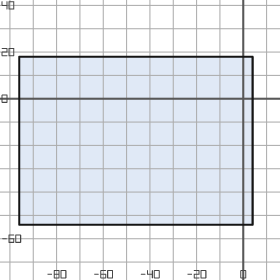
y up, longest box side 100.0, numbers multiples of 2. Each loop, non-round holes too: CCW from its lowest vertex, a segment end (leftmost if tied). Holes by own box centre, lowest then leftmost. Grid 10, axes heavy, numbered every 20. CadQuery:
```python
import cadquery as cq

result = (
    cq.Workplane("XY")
    .moveTo(-96.0, -54.0)
    .lineTo(4.0, -54.0)
    .lineTo(4.0, 18.0)
    .lineTo(-96.0, 18.0)
    .close()
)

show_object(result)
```